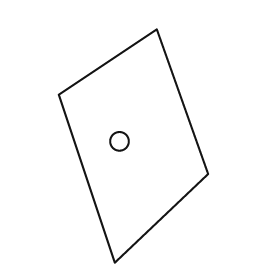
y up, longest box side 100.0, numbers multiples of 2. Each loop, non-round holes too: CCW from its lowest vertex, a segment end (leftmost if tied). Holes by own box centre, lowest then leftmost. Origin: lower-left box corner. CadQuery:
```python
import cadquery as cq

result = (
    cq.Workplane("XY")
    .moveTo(24.0, 0.0)
    .lineTo(64.0, 38.0)
    .lineTo(42.0, 100.0)
    .lineTo(0.0, 72.0)
    .close()
    .moveTo(26.0, 52.0)
    .circle(4.0)
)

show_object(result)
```